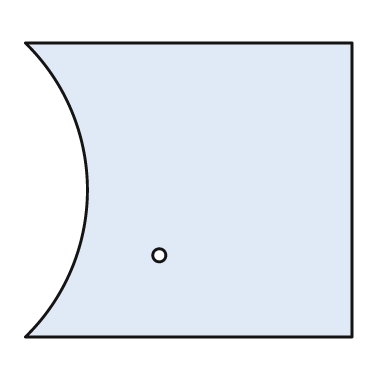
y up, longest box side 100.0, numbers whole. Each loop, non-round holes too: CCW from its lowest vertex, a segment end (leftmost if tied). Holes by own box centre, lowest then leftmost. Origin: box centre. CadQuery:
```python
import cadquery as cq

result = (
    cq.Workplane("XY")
    .moveTo(-50.0, -45.0)
    .lineTo(50.0, -45.0)
    .lineTo(50.0, 45.0)
    .lineTo(-50.0, 45.0)
    .threePointArc((-31.0, 0.0), (-50.0, -45.0))
    .close()
    .moveTo(-9.0, -20.0)
    .circle(2.0)
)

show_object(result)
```